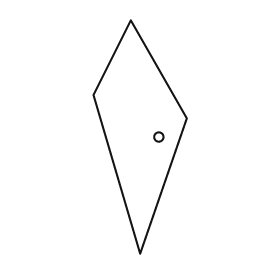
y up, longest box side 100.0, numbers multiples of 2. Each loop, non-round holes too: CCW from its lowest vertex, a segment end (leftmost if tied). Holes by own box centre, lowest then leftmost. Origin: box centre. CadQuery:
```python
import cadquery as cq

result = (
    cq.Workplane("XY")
    .moveTo(0.0, -50.0)
    .lineTo(20.0, 8.0)
    .lineTo(-4.0, 50.0)
    .lineTo(-20.0, 18.0)
    .close()
    .moveTo(8.0, 0.0)
    .circle(2.0)
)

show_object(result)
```